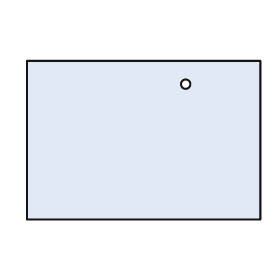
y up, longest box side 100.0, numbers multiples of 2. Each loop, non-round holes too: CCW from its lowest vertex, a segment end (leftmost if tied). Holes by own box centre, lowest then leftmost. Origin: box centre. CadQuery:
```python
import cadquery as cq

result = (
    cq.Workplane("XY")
    .moveTo(-50.0, -34.0)
    .lineTo(50.0, -34.0)
    .lineTo(50.0, 34.0)
    .lineTo(-50.0, 34.0)
    .close()
    .moveTo(18.0, 24.0)
    .circle(2.0)
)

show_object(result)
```